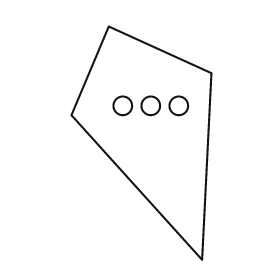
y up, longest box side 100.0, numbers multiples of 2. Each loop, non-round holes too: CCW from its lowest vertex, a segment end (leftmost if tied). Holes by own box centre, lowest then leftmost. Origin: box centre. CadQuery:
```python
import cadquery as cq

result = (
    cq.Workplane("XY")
    .moveTo(26.0, -50.0)
    .lineTo(30.0, 30.0)
    .lineTo(-14.0, 50.0)
    .lineTo(-30.0, 12.0)
    .close()
    .moveTo(-8.0, 16.0)
    .circle(4.0)
    .moveTo(4.0, 16.0)
    .circle(4.0)
    .moveTo(16.0, 16.0)
    .circle(4.0)
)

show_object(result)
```